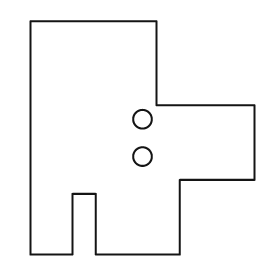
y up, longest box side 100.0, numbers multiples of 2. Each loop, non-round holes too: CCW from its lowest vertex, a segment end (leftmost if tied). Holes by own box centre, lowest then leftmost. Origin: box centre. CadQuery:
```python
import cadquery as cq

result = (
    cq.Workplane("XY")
    .moveTo(-48.0, -50.0)
    .lineTo(-30.0, -50.0)
    .lineTo(-30.0, -24.0)
    .lineTo(-20.0, -24.0)
    .lineTo(-20.0, -50.0)
    .lineTo(16.0, -50.0)
    .lineTo(16.0, -18.0)
    .lineTo(48.0, -18.0)
    .lineTo(48.0, 14.0)
    .lineTo(6.0, 14.0)
    .lineTo(6.0, 50.0)
    .lineTo(-48.0, 50.0)
    .close()
    .moveTo(0.0, -8.0)
    .circle(4.0)
    .moveTo(0.0, 8.0)
    .circle(4.0)
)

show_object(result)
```